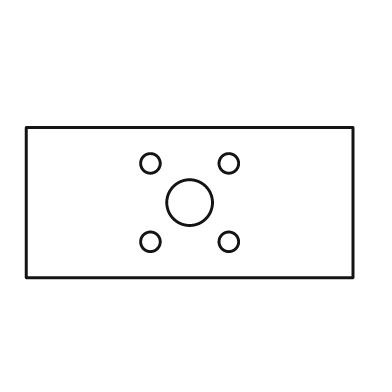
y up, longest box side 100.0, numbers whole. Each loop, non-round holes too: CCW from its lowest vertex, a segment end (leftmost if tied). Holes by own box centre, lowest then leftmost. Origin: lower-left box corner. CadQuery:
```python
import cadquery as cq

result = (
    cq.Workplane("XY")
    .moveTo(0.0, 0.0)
    .lineTo(100.0, 0.0)
    .lineTo(100.0, 46.0)
    .lineTo(0.0, 46.0)
    .close()
    .moveTo(38.0, 11.0)
    .circle(3.0)
    .moveTo(62.0, 11.0)
    .circle(3.0)
    .moveTo(50.0, 23.0)
    .circle(7.0)
    .moveTo(38.0, 35.0)
    .circle(3.0)
    .moveTo(62.0, 35.0)
    .circle(3.0)
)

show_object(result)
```